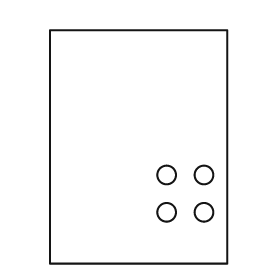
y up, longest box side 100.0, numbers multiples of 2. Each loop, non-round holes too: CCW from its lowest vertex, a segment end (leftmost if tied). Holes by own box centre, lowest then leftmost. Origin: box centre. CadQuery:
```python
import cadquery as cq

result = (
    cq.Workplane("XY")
    .moveTo(-38.0, -50.0)
    .lineTo(38.0, -50.0)
    .lineTo(38.0, 50.0)
    .lineTo(-38.0, 50.0)
    .close()
    .moveTo(12.0, -28.0)
    .circle(4.0)
    .moveTo(28.0, -28.0)
    .circle(4.0)
    .moveTo(12.0, -12.0)
    .circle(4.0)
    .moveTo(28.0, -12.0)
    .circle(4.0)
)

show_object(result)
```